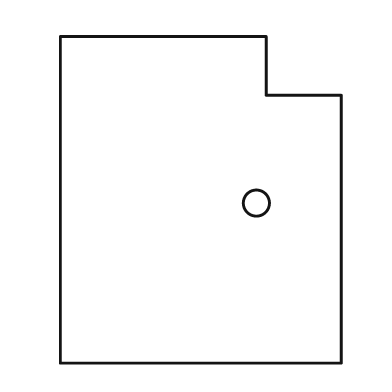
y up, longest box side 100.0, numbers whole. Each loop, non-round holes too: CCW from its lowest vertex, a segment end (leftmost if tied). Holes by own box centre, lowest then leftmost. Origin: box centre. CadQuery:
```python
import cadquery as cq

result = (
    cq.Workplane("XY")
    .moveTo(-43.0, -50.0)
    .lineTo(43.0, -50.0)
    .lineTo(43.0, 32.0)
    .lineTo(20.0, 32.0)
    .lineTo(20.0, 50.0)
    .lineTo(-43.0, 50.0)
    .close()
    .moveTo(17.0, -1.0)
    .circle(4.0)
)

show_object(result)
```